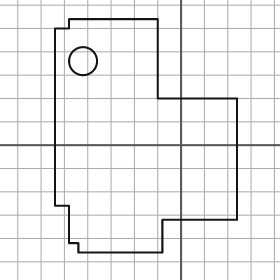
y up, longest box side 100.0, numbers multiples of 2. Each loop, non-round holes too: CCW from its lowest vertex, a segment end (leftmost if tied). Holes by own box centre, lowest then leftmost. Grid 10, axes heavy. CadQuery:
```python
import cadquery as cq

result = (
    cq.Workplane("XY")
    .moveTo(-44.0, -46.0)
    .lineTo(-8.0, -46.0)
    .lineTo(-8.0, -32.0)
    .lineTo(24.0, -32.0)
    .lineTo(24.0, 20.0)
    .lineTo(-10.0, 20.0)
    .lineTo(-10.0, 54.0)
    .lineTo(-48.0, 54.0)
    .lineTo(-48.0, 50.0)
    .lineTo(-54.0, 50.0)
    .lineTo(-54.0, -26.0)
    .lineTo(-48.0, -26.0)
    .lineTo(-48.0, -42.0)
    .lineTo(-44.0, -42.0)
    .close()
    .moveTo(-42.0, 36.0)
    .circle(6.0)
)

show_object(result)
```